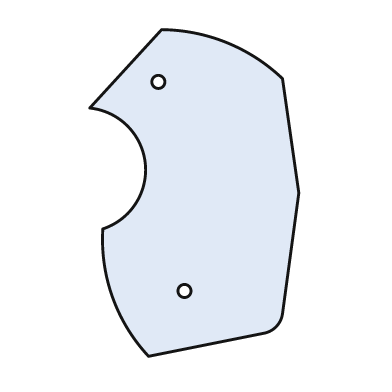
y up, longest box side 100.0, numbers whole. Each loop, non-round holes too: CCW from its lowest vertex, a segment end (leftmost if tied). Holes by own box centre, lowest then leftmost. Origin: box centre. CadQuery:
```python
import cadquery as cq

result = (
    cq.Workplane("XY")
    .moveTo(-14.0, -50.0)
    .lineTo(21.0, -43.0)
    .threePointArc((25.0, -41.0), (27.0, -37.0))
    .lineTo(32.0, 0.0)
    .lineTo(27.0, 35.0)
    .threePointArc((10.0, 46.0), (-10.0, 50.0))
    .lineTo(-32.0, 26.0)
    .threePointArc((-15.0, 9.0), (-28.0, -11.0))
    .threePointArc((-25.0, -32.0), (-14.0, -50.0))
    .close()
    .moveTo(-3.0, -30.0)
    .circle(2.0)
    .moveTo(-11.0, 34.0)
    .circle(2.0)
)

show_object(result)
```